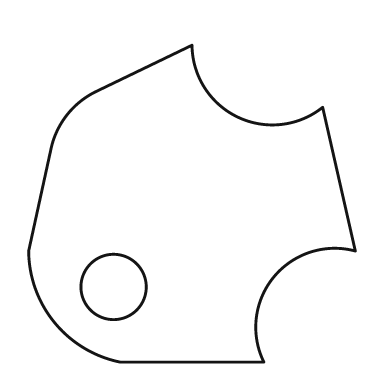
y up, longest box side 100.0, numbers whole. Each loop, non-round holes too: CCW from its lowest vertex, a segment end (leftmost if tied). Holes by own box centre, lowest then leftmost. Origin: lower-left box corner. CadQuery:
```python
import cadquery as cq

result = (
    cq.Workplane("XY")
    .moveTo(28.0, 0.0)
    .lineTo(72.0, 0.0)
    .threePointArc((75.0, 26.0), (100.0, 34.0))
    .lineTo(90.0, 78.0)
    .threePointArc((64.0, 75.0), (50.0, 97.0))
    .lineTo(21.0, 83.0)
    .threePointArc((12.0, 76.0), (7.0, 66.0))
    .lineTo(0.0, 34.0)
    .threePointArc((8.0, 12.0), (28.0, 0.0))
    .close()
    .moveTo(26.0, 23.0)
    .circle(10.0)
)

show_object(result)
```